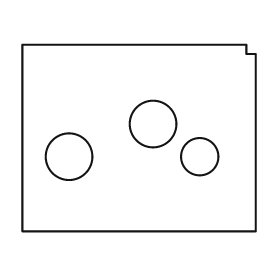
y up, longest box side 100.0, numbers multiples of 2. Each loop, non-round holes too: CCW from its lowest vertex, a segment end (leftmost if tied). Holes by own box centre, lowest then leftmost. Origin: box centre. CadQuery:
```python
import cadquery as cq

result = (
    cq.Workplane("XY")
    .moveTo(-50.0, -40.0)
    .lineTo(50.0, -40.0)
    .lineTo(50.0, 36.0)
    .lineTo(46.0, 36.0)
    .lineTo(46.0, 40.0)
    .lineTo(-50.0, 40.0)
    .close()
    .moveTo(-30.0, -8.0)
    .circle(10.0)
    .moveTo(26.0, -8.0)
    .circle(8.0)
    .moveTo(6.0, 6.0)
    .circle(10.0)
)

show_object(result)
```